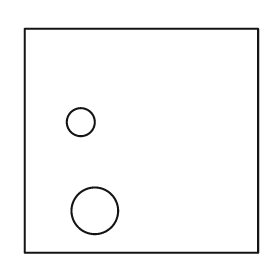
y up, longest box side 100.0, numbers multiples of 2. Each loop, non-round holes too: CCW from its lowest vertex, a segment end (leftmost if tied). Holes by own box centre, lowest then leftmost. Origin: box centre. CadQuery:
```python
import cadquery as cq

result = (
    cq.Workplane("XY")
    .moveTo(-50.0, -48.0)
    .lineTo(50.0, -48.0)
    .lineTo(50.0, 48.0)
    .lineTo(-50.0, 48.0)
    .close()
    .moveTo(-20.0, -30.0)
    .circle(10.0)
    .moveTo(-26.0, 8.0)
    .circle(6.0)
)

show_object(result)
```